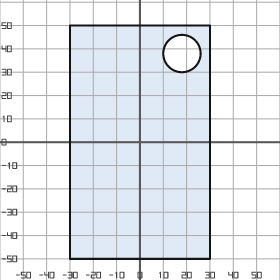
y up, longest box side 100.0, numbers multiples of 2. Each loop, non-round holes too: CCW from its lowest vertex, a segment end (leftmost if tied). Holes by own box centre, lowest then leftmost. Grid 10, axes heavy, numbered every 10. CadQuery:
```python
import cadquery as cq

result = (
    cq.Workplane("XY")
    .moveTo(-30.0, -50.0)
    .lineTo(30.0, -50.0)
    .lineTo(30.0, 50.0)
    .lineTo(-30.0, 50.0)
    .close()
    .moveTo(18.0, 38.0)
    .circle(8.0)
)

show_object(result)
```